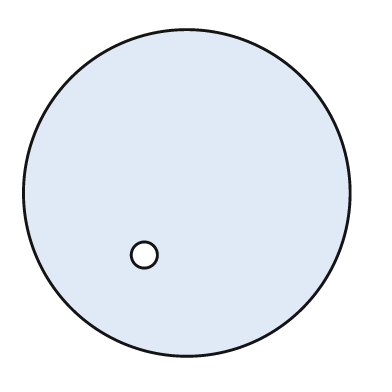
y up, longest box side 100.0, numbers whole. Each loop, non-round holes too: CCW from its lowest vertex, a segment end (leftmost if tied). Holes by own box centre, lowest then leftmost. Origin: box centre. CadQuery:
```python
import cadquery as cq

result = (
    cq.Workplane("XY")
    .moveTo(0.0, 0.0)
    .circle(50.0)
    .moveTo(-13.0, -19.0)
    .circle(4.0)
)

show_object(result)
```